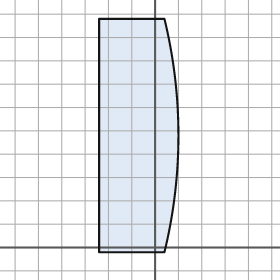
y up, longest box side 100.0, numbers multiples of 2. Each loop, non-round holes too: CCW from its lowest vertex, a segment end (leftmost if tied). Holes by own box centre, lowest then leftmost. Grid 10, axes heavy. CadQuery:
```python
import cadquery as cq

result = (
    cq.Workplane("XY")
    .moveTo(-24.0, -2.0)
    .lineTo(4.0, -2.0)
    .threePointArc((10.0, 48.0), (4.0, 98.0))
    .lineTo(-24.0, 98.0)
    .close()
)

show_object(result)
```